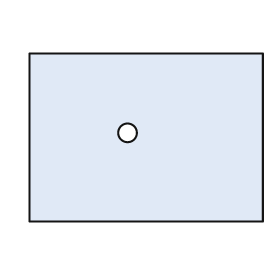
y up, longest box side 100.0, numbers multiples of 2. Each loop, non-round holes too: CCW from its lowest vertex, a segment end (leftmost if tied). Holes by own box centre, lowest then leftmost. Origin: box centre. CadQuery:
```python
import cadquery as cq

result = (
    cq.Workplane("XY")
    .moveTo(-50.0, -36.0)
    .lineTo(50.0, -36.0)
    .lineTo(50.0, 36.0)
    .lineTo(-50.0, 36.0)
    .close()
    .moveTo(-8.0, 2.0)
    .circle(4.0)
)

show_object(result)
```